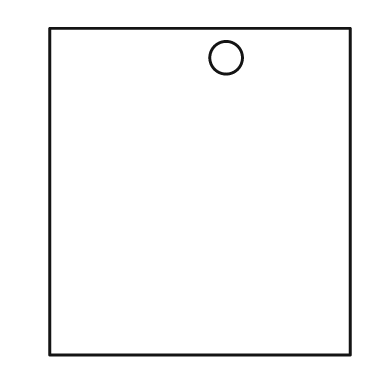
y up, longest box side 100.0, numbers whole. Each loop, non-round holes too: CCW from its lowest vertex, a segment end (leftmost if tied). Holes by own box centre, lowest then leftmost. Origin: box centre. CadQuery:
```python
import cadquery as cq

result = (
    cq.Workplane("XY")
    .moveTo(-46.0, -50.0)
    .lineTo(46.0, -50.0)
    .lineTo(46.0, 50.0)
    .lineTo(-46.0, 50.0)
    .close()
    .moveTo(8.0, 41.0)
    .circle(5.0)
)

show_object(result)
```